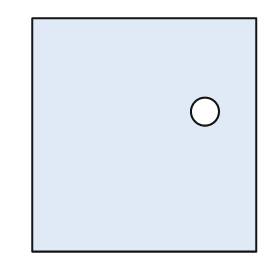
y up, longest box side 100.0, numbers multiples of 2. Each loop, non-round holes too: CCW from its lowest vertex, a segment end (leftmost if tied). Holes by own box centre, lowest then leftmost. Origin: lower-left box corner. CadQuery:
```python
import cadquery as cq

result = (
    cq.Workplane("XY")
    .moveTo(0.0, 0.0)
    .lineTo(96.0, 0.0)
    .lineTo(96.0, 100.0)
    .lineTo(0.0, 100.0)
    .close()
    .moveTo(74.0, 60.0)
    .circle(6.0)
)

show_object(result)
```